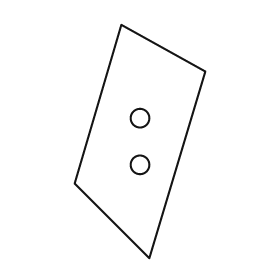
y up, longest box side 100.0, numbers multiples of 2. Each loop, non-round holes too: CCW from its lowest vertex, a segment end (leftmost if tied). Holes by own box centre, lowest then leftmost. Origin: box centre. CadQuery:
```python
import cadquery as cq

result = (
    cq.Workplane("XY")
    .moveTo(4.0, -50.0)
    .lineTo(28.0, 30.0)
    .lineTo(-8.0, 50.0)
    .lineTo(-28.0, -18.0)
    .close()
    .moveTo(0.0, -10.0)
    .circle(4.0)
    .moveTo(0.0, 10.0)
    .circle(4.0)
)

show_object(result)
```